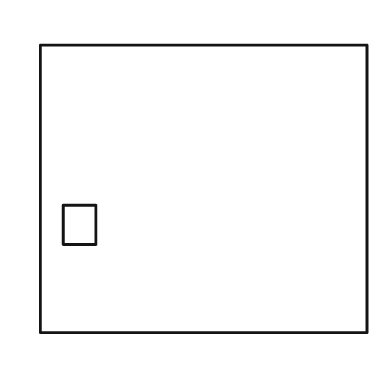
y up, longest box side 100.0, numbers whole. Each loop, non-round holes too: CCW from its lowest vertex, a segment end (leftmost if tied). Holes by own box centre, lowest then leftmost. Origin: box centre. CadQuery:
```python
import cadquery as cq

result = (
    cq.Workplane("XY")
    .moveTo(-50.0, -44.0)
    .lineTo(50.0, -44.0)
    .lineTo(50.0, 44.0)
    .lineTo(-50.0, 44.0)
    .close()
    .moveTo(-43.0, -17.0)
    .lineTo(-33.0, -17.0)
    .lineTo(-33.0, -5.0)
    .lineTo(-43.0, -5.0)
    .close()
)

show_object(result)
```